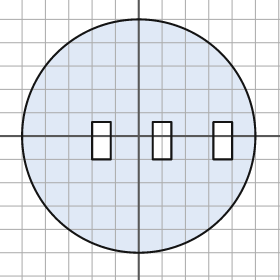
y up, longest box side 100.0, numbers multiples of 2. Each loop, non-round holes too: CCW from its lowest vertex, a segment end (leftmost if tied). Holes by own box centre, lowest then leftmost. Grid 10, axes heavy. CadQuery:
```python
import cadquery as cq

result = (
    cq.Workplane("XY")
    .moveTo(0.0, 0.0)
    .circle(50.0)
    .moveTo(-20.0, -10.0)
    .lineTo(-12.0, -10.0)
    .lineTo(-12.0, 6.0)
    .lineTo(-20.0, 6.0)
    .close()
    .moveTo(6.0, -10.0)
    .lineTo(14.0, -10.0)
    .lineTo(14.0, 6.0)
    .lineTo(6.0, 6.0)
    .close()
    .moveTo(32.0, -10.0)
    .lineTo(40.0, -10.0)
    .lineTo(40.0, 6.0)
    .lineTo(32.0, 6.0)
    .close()
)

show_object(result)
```